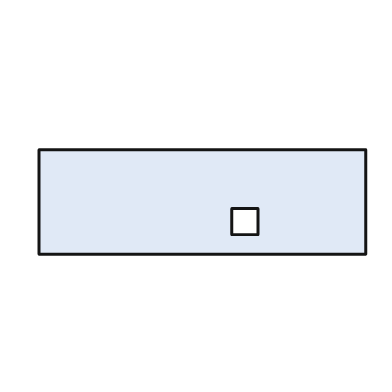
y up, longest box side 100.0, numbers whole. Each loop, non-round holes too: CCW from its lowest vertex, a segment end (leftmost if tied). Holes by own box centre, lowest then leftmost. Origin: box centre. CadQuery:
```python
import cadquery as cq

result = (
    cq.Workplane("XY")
    .moveTo(-50.0, -16.0)
    .lineTo(50.0, -16.0)
    .lineTo(50.0, 16.0)
    .lineTo(-50.0, 16.0)
    .close()
    .moveTo(9.0, -10.0)
    .lineTo(17.0, -10.0)
    .lineTo(17.0, -2.0)
    .lineTo(9.0, -2.0)
    .close()
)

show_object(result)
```